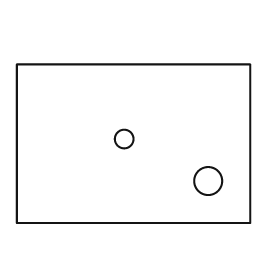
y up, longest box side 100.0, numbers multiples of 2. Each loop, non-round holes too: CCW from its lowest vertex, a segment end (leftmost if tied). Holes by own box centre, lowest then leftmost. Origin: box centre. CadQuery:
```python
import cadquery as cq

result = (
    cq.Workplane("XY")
    .moveTo(-50.0, -34.0)
    .lineTo(50.0, -34.0)
    .lineTo(50.0, 34.0)
    .lineTo(-50.0, 34.0)
    .close()
    .moveTo(32.0, -16.0)
    .circle(6.0)
    .moveTo(-4.0, 2.0)
    .circle(4.0)
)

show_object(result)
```